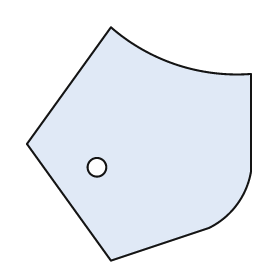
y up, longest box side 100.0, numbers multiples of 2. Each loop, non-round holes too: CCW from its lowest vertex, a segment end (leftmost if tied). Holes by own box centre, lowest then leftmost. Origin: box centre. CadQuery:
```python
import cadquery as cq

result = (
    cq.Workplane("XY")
    .moveTo(-12.0, -50.0)
    .lineTo(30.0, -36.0)
    .threePointArc((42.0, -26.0), (48.0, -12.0))
    .lineTo(48.0, 30.0)
    .threePointArc((16.0, 34.0), (-12.0, 50.0))
    .lineTo(-48.0, 0.0)
    .close()
    .moveTo(-18.0, -10.0)
    .circle(4.0)
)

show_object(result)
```